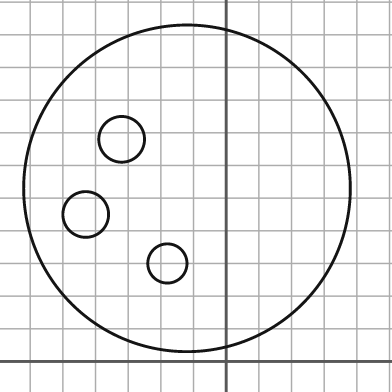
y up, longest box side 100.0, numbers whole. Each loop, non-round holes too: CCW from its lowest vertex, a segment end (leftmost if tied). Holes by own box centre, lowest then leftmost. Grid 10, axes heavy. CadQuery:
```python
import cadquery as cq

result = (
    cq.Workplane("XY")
    .moveTo(-12.0, 53.0)
    .circle(50.0)
    .moveTo(-18.0, 30.0)
    .circle(6.0)
    .moveTo(-43.0, 45.0)
    .circle(7.0)
    .moveTo(-32.0, 68.0)
    .circle(7.0)
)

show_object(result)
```